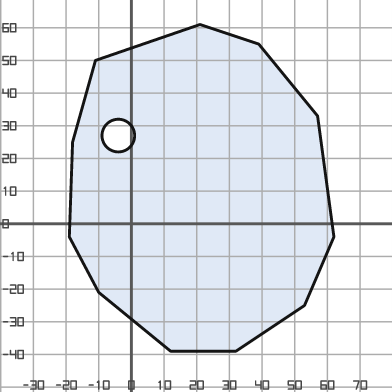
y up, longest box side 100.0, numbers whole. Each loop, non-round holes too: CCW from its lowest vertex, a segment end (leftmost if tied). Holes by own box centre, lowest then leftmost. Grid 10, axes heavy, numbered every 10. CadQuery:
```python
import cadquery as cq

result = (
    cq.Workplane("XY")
    .moveTo(12.0, -39.0)
    .lineTo(32.0, -39.0)
    .lineTo(53.0, -25.0)
    .lineTo(62.0, -4.0)
    .lineTo(57.0, 33.0)
    .lineTo(39.0, 55.0)
    .lineTo(21.0, 61.0)
    .lineTo(-11.0, 50.0)
    .lineTo(-18.0, 25.0)
    .lineTo(-19.0, -4.0)
    .lineTo(-10.0, -21.0)
    .close()
    .moveTo(-4.0, 27.0)
    .circle(5.0)
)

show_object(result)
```